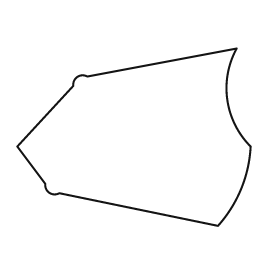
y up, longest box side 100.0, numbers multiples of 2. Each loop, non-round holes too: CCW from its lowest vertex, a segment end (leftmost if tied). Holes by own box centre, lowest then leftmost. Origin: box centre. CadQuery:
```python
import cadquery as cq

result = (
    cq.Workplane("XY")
    .moveTo(36.0, -38.0)
    .threePointArc((46.0, -22.0), (50.0, -4.0))
    .threePointArc((40.0, 16.0), (44.0, 38.0))
    .lineTo(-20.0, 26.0)
    .threePointArc((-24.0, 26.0), (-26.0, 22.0))
    .lineTo(-50.0, -4.0)
    .lineTo(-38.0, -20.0)
    .threePointArc((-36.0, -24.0), (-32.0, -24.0))
    .close()
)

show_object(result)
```